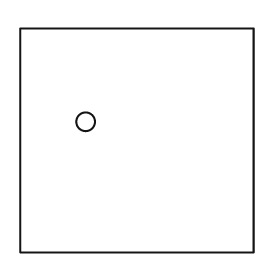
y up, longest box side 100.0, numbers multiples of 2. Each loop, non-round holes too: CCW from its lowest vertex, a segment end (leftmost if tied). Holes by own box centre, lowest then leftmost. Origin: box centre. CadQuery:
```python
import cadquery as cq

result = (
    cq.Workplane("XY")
    .moveTo(-50.0, -48.0)
    .lineTo(50.0, -48.0)
    .lineTo(50.0, 48.0)
    .lineTo(-50.0, 48.0)
    .close()
    .moveTo(-22.0, 8.0)
    .circle(4.0)
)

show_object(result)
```